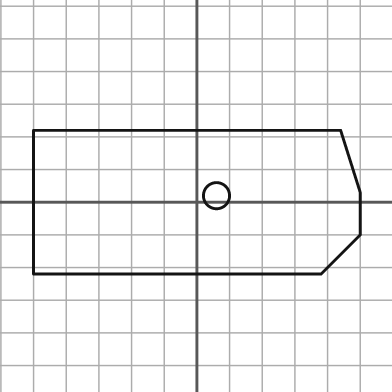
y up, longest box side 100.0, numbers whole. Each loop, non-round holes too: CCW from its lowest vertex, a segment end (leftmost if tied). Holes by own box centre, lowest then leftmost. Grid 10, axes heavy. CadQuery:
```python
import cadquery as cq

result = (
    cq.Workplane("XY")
    .moveTo(-50.0, -22.0)
    .lineTo(38.0, -22.0)
    .lineTo(50.0, -10.0)
    .lineTo(50.0, 3.0)
    .lineTo(44.0, 22.0)
    .lineTo(-50.0, 22.0)
    .close()
    .moveTo(6.0, 2.0)
    .circle(4.0)
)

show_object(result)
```